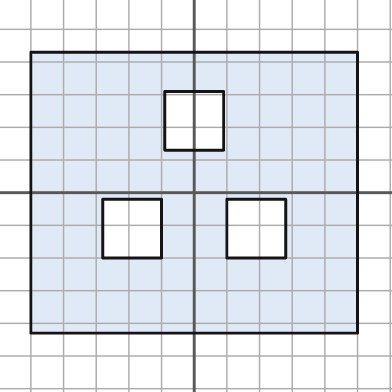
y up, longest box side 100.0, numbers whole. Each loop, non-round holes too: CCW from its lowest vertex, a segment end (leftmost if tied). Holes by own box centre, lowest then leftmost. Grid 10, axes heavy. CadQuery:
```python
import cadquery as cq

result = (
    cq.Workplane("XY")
    .moveTo(-50.0, -43.0)
    .lineTo(50.0, -43.0)
    .lineTo(50.0, 43.0)
    .lineTo(-50.0, 43.0)
    .close()
    .moveTo(-28.0, -20.0)
    .lineTo(-10.0, -20.0)
    .lineTo(-10.0, -2.0)
    .lineTo(-28.0, -2.0)
    .close()
    .moveTo(10.0, -20.0)
    .lineTo(28.0, -20.0)
    .lineTo(28.0, -2.0)
    .lineTo(10.0, -2.0)
    .close()
    .moveTo(-9.0, 13.0)
    .lineTo(9.0, 13.0)
    .lineTo(9.0, 31.0)
    .lineTo(-9.0, 31.0)
    .close()
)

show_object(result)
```